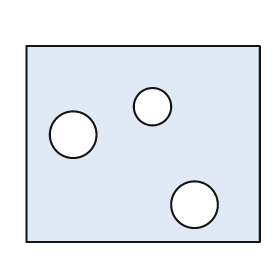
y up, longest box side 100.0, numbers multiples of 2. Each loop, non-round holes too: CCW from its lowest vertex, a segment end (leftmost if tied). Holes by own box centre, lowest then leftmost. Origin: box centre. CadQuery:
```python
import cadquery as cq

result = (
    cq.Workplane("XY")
    .moveTo(-50.0, -42.0)
    .lineTo(50.0, -42.0)
    .lineTo(50.0, 42.0)
    .lineTo(-50.0, 42.0)
    .close()
    .moveTo(22.0, -26.0)
    .circle(10.0)
    .moveTo(-30.0, 4.0)
    .circle(10.0)
    .moveTo(4.0, 16.0)
    .circle(8.0)
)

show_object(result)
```